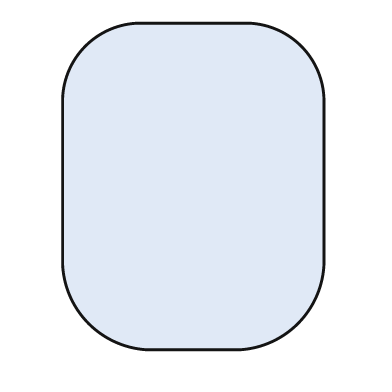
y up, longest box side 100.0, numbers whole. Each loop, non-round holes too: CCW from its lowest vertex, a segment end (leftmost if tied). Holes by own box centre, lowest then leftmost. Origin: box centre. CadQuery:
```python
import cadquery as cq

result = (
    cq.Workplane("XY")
    .moveTo(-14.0, -50.0)
    .lineTo(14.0, -50.0)
    .threePointArc((32.0, -42.0), (40.0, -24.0))
    .lineTo(40.0, 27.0)
    .threePointArc((33.0, 43.0), (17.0, 50.0))
    .lineTo(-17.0, 50.0)
    .threePointArc((-33.0, 43.0), (-40.0, 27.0))
    .lineTo(-40.0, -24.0)
    .threePointArc((-32.0, -42.0), (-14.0, -50.0))
    .close()
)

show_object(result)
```